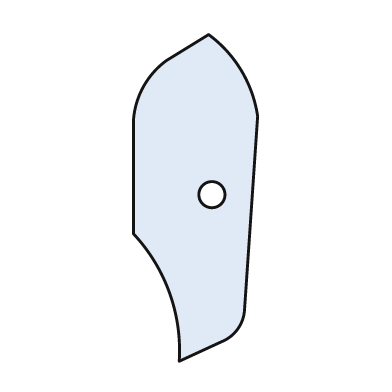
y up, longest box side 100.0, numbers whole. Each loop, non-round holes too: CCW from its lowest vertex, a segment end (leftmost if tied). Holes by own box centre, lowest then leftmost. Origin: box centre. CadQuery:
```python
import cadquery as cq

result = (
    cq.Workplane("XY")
    .moveTo(-5.0, -50.0)
    .lineTo(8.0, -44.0)
    .threePointArc((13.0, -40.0), (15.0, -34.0))
    .lineTo(19.0, 25.0)
    .threePointArc((14.0, 39.0), (4.0, 50.0))
    .lineTo(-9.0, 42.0)
    .threePointArc((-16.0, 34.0), (-19.0, 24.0))
    .lineTo(-19.0, -11.0)
    .threePointArc((-8.0, -29.0), (-5.0, -50.0))
    .close()
    .moveTo(5.0, 1.0)
    .circle(4.0)
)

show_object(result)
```